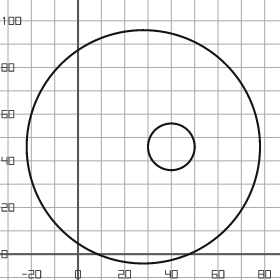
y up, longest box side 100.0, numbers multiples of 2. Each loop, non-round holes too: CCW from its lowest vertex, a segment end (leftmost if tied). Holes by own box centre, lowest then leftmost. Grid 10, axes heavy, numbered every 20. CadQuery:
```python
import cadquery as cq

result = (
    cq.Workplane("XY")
    .moveTo(28.0, 46.0)
    .circle(50.0)
    .moveTo(40.0, 46.0)
    .circle(10.0)
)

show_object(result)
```